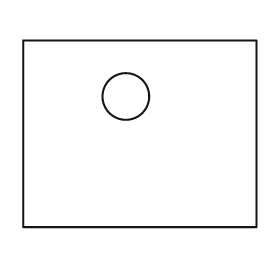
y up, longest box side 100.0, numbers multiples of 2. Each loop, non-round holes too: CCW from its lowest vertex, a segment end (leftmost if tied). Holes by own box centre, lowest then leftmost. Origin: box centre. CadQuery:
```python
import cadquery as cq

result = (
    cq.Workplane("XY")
    .moveTo(-50.0, -40.0)
    .lineTo(50.0, -40.0)
    .lineTo(50.0, 40.0)
    .lineTo(-50.0, 40.0)
    .close()
    .moveTo(-6.0, 16.0)
    .circle(10.0)
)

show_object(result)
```